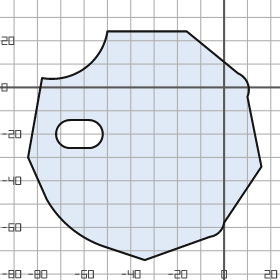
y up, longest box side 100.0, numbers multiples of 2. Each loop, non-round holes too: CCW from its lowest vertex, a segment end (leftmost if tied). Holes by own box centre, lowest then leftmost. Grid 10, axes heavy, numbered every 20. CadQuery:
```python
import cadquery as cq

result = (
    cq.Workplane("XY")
    .moveTo(-34.0, -74.0)
    .lineTo(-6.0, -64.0)
    .threePointArc((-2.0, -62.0), (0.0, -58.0))
    .lineTo(16.0, -34.0)
    .lineTo(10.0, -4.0)
    .threePointArc((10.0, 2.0), (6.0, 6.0))
    .lineTo(-16.0, 24.0)
    .lineTo(-50.0, 24.0)
    .threePointArc((-60.0, 8.0), (-78.0, 4.0))
    .lineTo(-84.0, -30.0)
    .lineTo(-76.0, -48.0)
    .threePointArc((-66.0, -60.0), (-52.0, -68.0))
    .close()
    .moveTo(-66.0, -26.0)
    .lineTo(-58.0, -26.0)
    .threePointArc((-52.0, -20.0), (-58.0, -14.0))
    .lineTo(-66.0, -14.0)
    .threePointArc((-72.0, -20.0), (-66.0, -26.0))
    .close()
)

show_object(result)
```